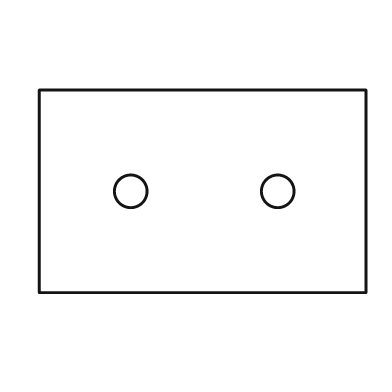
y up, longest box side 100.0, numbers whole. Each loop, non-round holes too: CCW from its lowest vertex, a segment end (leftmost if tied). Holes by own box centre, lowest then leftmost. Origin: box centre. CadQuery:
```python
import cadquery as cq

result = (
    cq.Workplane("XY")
    .moveTo(-50.0, -31.0)
    .lineTo(50.0, -31.0)
    .lineTo(50.0, 31.0)
    .lineTo(-50.0, 31.0)
    .close()
    .moveTo(-22.0, 0.0)
    .circle(5.0)
    .moveTo(23.0, 0.0)
    .circle(5.0)
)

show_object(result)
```